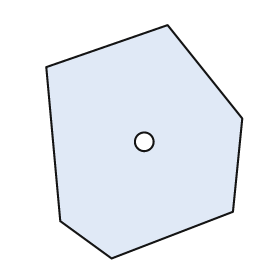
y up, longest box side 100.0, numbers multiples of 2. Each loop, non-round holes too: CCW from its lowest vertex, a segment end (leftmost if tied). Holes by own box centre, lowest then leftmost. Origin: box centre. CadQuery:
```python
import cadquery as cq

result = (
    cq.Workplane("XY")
    .moveTo(-14.0, -50.0)
    .lineTo(38.0, -30.0)
    .lineTo(42.0, 10.0)
    .lineTo(10.0, 50.0)
    .lineTo(-42.0, 32.0)
    .lineTo(-36.0, -34.0)
    .close()
    .moveTo(0.0, 0.0)
    .circle(4.0)
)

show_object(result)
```